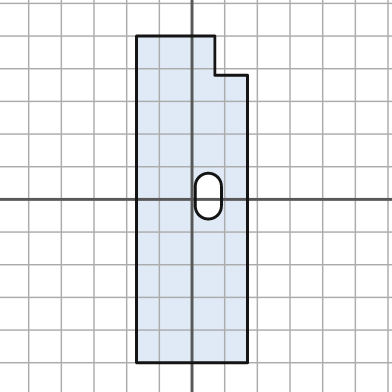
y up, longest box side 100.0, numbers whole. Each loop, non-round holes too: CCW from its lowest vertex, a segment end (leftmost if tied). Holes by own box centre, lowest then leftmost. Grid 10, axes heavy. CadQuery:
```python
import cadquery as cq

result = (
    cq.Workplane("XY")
    .moveTo(-17.0, -50.0)
    .lineTo(17.0, -50.0)
    .lineTo(17.0, 38.0)
    .lineTo(7.0, 38.0)
    .lineTo(7.0, 50.0)
    .lineTo(-17.0, 50.0)
    .close()
    .moveTo(1.0, -2.0)
    .threePointArc((5.0, -6.0), (9.0, -2.0))
    .lineTo(9.0, 4.0)
    .threePointArc((5.0, 8.0), (1.0, 4.0))
    .close()
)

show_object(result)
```